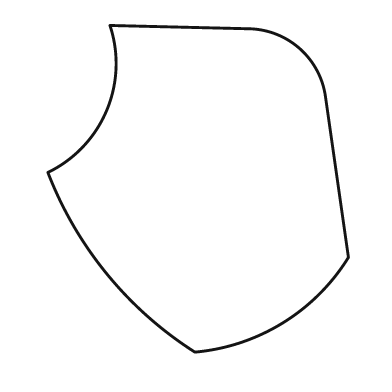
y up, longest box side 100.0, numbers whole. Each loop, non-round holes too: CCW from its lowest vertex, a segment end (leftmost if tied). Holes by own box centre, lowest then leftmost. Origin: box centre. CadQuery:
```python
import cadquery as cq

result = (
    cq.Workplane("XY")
    .moveTo(-1.0, -50.0)
    .threePointArc((26.0, -41.0), (46.0, -21.0))
    .lineTo(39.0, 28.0)
    .threePointArc((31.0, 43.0), (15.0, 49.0))
    .lineTo(-27.0, 50.0)
    .threePointArc((-28.0, 24.0), (-46.0, 5.0))
    .threePointArc((-28.0, -26.0), (-1.0, -50.0))
    .close()
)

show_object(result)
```